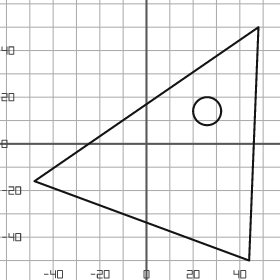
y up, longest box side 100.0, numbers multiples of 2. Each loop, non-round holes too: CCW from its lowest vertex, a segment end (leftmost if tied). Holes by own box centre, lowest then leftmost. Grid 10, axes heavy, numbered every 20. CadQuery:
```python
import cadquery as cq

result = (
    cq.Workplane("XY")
    .moveTo(44.0, -50.0)
    .lineTo(48.0, 50.0)
    .lineTo(-48.0, -16.0)
    .close()
    .moveTo(26.0, 14.0)
    .circle(6.0)
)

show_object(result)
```